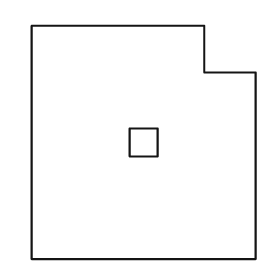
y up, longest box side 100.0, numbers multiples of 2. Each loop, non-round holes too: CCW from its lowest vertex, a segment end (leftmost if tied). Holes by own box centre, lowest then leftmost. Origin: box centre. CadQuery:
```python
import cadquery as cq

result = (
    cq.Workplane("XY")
    .moveTo(-48.0, -50.0)
    .lineTo(48.0, -50.0)
    .lineTo(48.0, 30.0)
    .lineTo(26.0, 30.0)
    .lineTo(26.0, 50.0)
    .lineTo(-48.0, 50.0)
    .close()
    .moveTo(-6.0, -6.0)
    .lineTo(6.0, -6.0)
    .lineTo(6.0, 6.0)
    .lineTo(-6.0, 6.0)
    .close()
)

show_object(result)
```